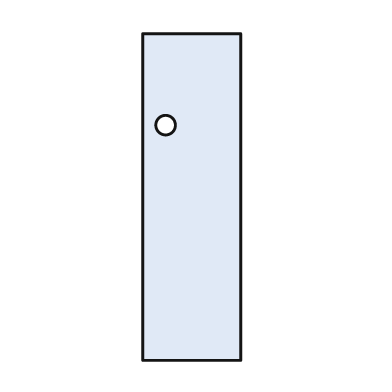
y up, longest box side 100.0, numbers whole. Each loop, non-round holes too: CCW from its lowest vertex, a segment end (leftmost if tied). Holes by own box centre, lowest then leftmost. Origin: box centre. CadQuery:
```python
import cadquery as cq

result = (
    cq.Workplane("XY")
    .moveTo(-15.0, -50.0)
    .lineTo(15.0, -50.0)
    .lineTo(15.0, 50.0)
    .lineTo(-15.0, 50.0)
    .close()
    .moveTo(-8.0, 22.0)
    .circle(3.0)
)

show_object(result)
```